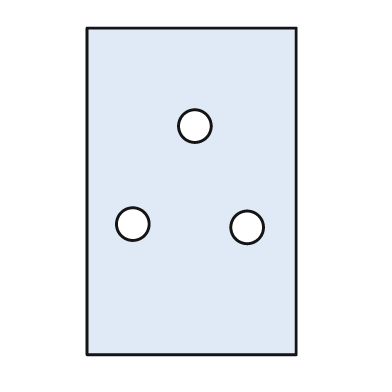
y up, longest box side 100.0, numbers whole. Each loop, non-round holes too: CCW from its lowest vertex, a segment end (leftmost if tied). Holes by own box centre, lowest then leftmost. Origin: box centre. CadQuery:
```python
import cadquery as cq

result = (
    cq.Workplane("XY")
    .moveTo(-32.0, -50.0)
    .lineTo(32.0, -50.0)
    .lineTo(32.0, 50.0)
    .lineTo(-32.0, 50.0)
    .close()
    .moveTo(17.0, -11.0)
    .circle(5.0)
    .moveTo(-18.0, -10.0)
    .circle(5.0)
    .moveTo(1.0, 20.0)
    .circle(5.0)
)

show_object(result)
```